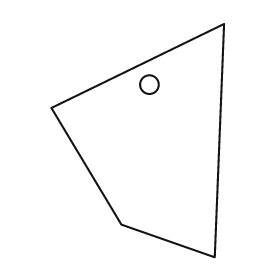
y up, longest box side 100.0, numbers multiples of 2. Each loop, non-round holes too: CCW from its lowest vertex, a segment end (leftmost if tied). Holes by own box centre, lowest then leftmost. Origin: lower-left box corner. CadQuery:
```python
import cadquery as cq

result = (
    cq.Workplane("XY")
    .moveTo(70.0, 0.0)
    .lineTo(74.0, 100.0)
    .lineTo(0.0, 64.0)
    .lineTo(30.0, 14.0)
    .close()
    .moveTo(42.0, 74.0)
    .circle(4.0)
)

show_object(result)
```